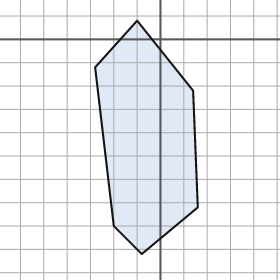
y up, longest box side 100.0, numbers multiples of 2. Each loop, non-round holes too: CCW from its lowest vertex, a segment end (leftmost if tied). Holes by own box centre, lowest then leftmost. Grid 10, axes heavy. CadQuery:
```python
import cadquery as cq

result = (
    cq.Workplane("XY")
    .moveTo(-8.0, -92.0)
    .lineTo(16.0, -72.0)
    .lineTo(14.0, -22.0)
    .lineTo(-10.0, 8.0)
    .lineTo(-28.0, -12.0)
    .lineTo(-20.0, -80.0)
    .close()
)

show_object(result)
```